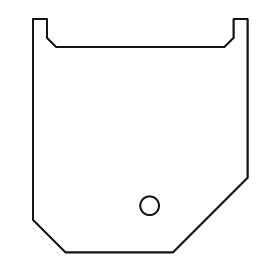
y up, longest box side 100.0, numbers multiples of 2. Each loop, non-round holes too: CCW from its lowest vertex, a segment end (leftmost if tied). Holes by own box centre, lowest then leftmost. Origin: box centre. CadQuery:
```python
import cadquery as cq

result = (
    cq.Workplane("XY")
    .moveTo(-32.0, -50.0)
    .lineTo(14.0, -50.0)
    .lineTo(46.0, -18.0)
    .lineTo(46.0, 50.0)
    .lineTo(40.0, 50.0)
    .lineTo(40.0, 42.0)
    .lineTo(36.0, 38.0)
    .lineTo(-36.0, 38.0)
    .lineTo(-40.0, 42.0)
    .lineTo(-40.0, 50.0)
    .lineTo(-46.0, 50.0)
    .lineTo(-46.0, -36.0)
    .close()
    .moveTo(4.0, -30.0)
    .circle(4.0)
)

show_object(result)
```